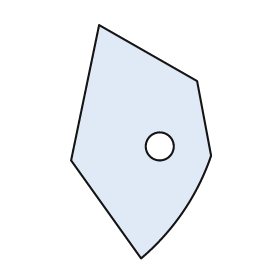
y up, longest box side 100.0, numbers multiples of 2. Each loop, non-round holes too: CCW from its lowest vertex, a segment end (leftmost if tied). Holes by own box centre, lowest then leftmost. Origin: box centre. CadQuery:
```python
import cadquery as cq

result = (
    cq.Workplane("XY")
    .moveTo(0.0, -50.0)
    .threePointArc((18.0, -30.0), (30.0, -6.0))
    .lineTo(24.0, 26.0)
    .lineTo(-18.0, 50.0)
    .lineTo(-30.0, -8.0)
    .close()
    .moveTo(8.0, -2.0)
    .circle(6.0)
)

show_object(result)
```